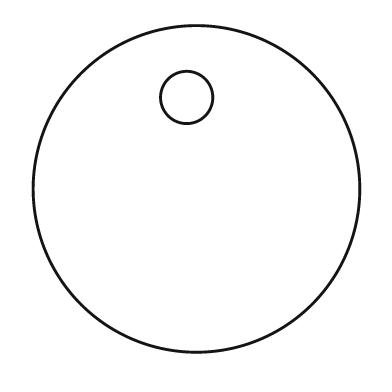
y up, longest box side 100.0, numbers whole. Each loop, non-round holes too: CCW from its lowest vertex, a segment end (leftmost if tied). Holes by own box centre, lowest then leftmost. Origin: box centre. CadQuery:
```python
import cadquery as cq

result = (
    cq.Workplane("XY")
    .moveTo(0.0, 0.0)
    .circle(50.0)
    .moveTo(-3.0, 28.0)
    .circle(8.0)
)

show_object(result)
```